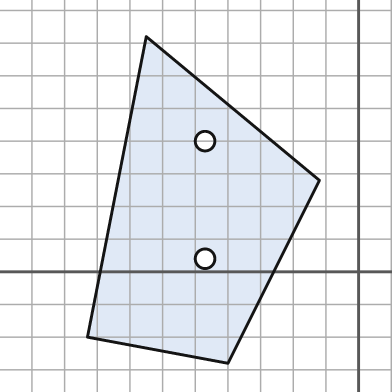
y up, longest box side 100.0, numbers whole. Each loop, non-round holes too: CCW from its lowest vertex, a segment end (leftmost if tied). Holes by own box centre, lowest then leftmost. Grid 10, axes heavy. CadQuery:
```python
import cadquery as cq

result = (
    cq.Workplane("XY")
    .moveTo(-40.0, -28.0)
    .lineTo(-12.0, 28.0)
    .lineTo(-65.0, 72.0)
    .lineTo(-83.0, -20.0)
    .close()
    .moveTo(-47.0, 4.0)
    .circle(3.0)
    .moveTo(-47.0, 40.0)
    .circle(3.0)
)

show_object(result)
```